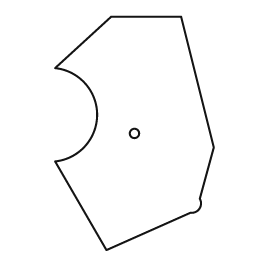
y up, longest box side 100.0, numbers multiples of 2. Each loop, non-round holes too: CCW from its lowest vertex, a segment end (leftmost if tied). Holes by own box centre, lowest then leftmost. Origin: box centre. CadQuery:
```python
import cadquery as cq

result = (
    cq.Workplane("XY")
    .moveTo(-12.0, -50.0)
    .lineTo(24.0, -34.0)
    .threePointArc((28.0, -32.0), (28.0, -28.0))
    .lineTo(34.0, -6.0)
    .lineTo(20.0, 50.0)
    .lineTo(-10.0, 50.0)
    .lineTo(-34.0, 28.0)
    .threePointArc((-16.0, 8.0), (-34.0, -12.0))
    .close()
    .moveTo(0.0, 0.0)
    .circle(2.0)
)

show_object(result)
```